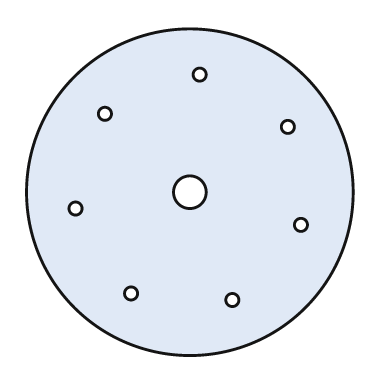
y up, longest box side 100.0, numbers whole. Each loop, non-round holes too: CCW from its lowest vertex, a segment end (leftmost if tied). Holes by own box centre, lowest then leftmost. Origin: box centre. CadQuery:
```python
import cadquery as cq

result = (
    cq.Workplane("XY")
    .moveTo(0.0, 0.0)
    .circle(50.0)
    .moveTo(13.0, -33.0)
    .circle(2.0)
    .moveTo(-18.0, -31.0)
    .circle(2.0)
    .moveTo(34.0, -10.0)
    .circle(2.0)
    .moveTo(-35.0, -5.0)
    .circle(2.0)
    .moveTo(0.0, 0.0)
    .circle(5.0)
    .moveTo(30.0, 20.0)
    .circle(2.0)
    .moveTo(-26.0, 24.0)
    .circle(2.0)
    .moveTo(3.0, 36.0)
    .circle(2.0)
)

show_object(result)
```